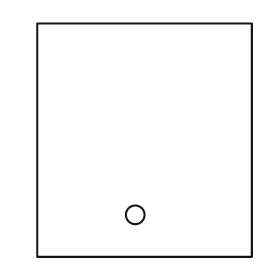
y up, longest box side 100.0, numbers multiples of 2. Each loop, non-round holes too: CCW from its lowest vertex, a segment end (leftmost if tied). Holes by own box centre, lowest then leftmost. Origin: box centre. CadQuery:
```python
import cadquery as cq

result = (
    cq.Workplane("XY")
    .moveTo(-46.0, -50.0)
    .lineTo(46.0, -50.0)
    .lineTo(46.0, 50.0)
    .lineTo(-46.0, 50.0)
    .close()
    .moveTo(-4.0, -32.0)
    .circle(4.0)
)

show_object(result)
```